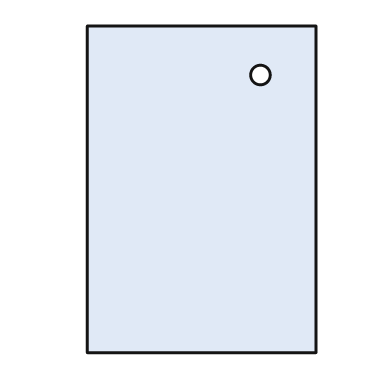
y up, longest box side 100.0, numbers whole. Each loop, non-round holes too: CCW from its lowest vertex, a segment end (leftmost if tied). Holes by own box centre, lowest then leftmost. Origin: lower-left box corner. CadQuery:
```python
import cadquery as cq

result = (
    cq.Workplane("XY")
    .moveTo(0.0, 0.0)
    .lineTo(70.0, 0.0)
    .lineTo(70.0, 100.0)
    .lineTo(0.0, 100.0)
    .close()
    .moveTo(53.0, 85.0)
    .circle(3.0)
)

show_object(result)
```